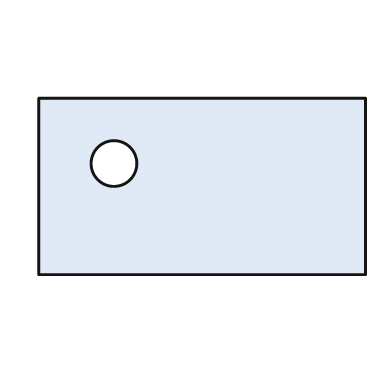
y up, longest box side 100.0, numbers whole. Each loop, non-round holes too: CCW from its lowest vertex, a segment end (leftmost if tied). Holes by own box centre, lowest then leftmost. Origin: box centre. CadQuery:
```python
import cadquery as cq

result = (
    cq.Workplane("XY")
    .moveTo(-50.0, -27.0)
    .lineTo(50.0, -27.0)
    .lineTo(50.0, 27.0)
    .lineTo(-50.0, 27.0)
    .close()
    .moveTo(-27.0, 7.0)
    .circle(7.0)
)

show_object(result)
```